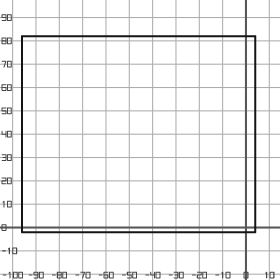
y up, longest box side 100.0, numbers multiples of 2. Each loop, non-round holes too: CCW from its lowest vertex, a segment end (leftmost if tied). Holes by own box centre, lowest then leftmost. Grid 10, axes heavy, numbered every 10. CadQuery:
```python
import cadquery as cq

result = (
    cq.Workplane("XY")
    .moveTo(-96.0, -2.0)
    .lineTo(4.0, -2.0)
    .lineTo(4.0, 82.0)
    .lineTo(-96.0, 82.0)
    .close()
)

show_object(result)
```